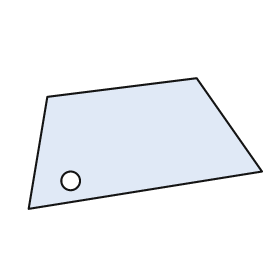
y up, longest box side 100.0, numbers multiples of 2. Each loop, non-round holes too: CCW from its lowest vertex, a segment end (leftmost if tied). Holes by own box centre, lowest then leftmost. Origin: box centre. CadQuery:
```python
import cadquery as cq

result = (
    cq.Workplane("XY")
    .moveTo(-50.0, -28.0)
    .lineTo(50.0, -12.0)
    .lineTo(22.0, 28.0)
    .lineTo(-42.0, 20.0)
    .close()
    .moveTo(-32.0, -16.0)
    .circle(4.0)
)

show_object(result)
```